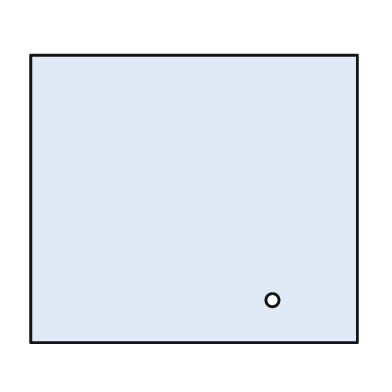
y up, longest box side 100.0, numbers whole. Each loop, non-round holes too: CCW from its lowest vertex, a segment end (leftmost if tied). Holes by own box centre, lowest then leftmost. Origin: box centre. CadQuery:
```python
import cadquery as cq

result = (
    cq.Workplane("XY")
    .moveTo(-50.0, -44.0)
    .lineTo(50.0, -44.0)
    .lineTo(50.0, 44.0)
    .lineTo(-50.0, 44.0)
    .close()
    .moveTo(24.0, -31.0)
    .circle(2.0)
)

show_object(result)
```